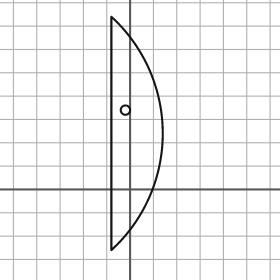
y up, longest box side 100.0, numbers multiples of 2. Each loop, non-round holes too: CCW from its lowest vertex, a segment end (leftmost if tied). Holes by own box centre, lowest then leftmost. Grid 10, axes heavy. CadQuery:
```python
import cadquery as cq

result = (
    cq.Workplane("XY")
    .moveTo(-8.0, -26.0)
    .threePointArc((14.0, 24.0), (-8.0, 74.0))
    .close()
    .moveTo(-2.0, 34.0)
    .circle(2.0)
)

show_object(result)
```